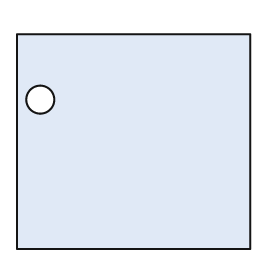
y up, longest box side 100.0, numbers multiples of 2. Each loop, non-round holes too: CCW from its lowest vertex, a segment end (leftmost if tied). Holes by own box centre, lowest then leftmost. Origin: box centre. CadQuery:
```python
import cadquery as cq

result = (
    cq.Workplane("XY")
    .moveTo(-50.0, -46.0)
    .lineTo(50.0, -46.0)
    .lineTo(50.0, 46.0)
    .lineTo(-50.0, 46.0)
    .close()
    .moveTo(-40.0, 18.0)
    .circle(6.0)
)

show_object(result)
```